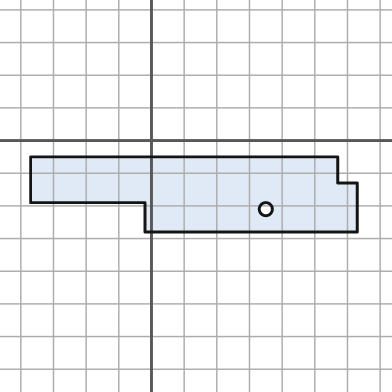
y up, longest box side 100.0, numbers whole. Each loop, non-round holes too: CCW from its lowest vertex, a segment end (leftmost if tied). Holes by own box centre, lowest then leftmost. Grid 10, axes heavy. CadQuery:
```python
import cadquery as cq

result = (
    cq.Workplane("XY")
    .moveTo(-2.0, -28.0)
    .lineTo(63.0, -28.0)
    .lineTo(63.0, -13.0)
    .lineTo(57.0, -13.0)
    .lineTo(57.0, -5.0)
    .lineTo(-37.0, -5.0)
    .lineTo(-37.0, -19.0)
    .lineTo(-2.0, -19.0)
    .close()
    .moveTo(35.0, -21.0)
    .circle(2.0)
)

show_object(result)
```